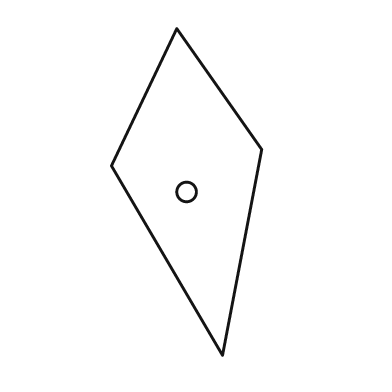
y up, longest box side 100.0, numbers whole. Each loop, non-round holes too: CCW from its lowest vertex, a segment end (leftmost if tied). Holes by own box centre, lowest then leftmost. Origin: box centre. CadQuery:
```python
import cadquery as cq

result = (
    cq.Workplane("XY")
    .moveTo(11.0, -50.0)
    .lineTo(23.0, 13.0)
    .lineTo(-3.0, 50.0)
    .lineTo(-23.0, 8.0)
    .close()
    .moveTo(0.0, 0.0)
    .circle(3.0)
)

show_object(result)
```